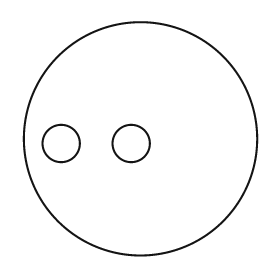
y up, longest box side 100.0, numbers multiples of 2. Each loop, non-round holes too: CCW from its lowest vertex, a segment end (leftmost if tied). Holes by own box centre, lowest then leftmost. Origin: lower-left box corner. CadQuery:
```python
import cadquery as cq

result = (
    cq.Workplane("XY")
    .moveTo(50.0, 50.0)
    .circle(50.0)
    .moveTo(16.0, 48.0)
    .circle(8.0)
    .moveTo(46.0, 48.0)
    .circle(8.0)
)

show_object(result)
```